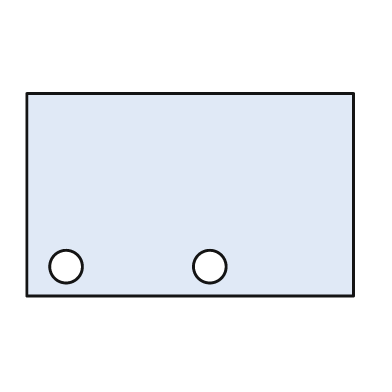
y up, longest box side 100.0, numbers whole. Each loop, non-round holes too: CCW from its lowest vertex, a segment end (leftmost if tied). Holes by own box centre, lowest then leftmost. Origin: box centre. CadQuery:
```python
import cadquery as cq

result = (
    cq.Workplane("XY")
    .moveTo(-50.0, -31.0)
    .lineTo(50.0, -31.0)
    .lineTo(50.0, 31.0)
    .lineTo(-50.0, 31.0)
    .close()
    .moveTo(-38.0, -22.0)
    .circle(5.0)
    .moveTo(6.0, -22.0)
    .circle(5.0)
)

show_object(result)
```